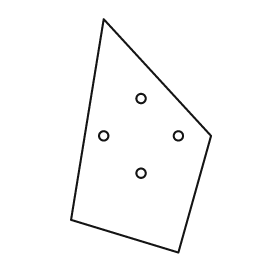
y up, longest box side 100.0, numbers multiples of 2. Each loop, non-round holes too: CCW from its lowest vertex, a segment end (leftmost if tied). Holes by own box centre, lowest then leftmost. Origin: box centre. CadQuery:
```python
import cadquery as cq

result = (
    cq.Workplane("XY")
    .moveTo(16.0, -50.0)
    .lineTo(30.0, 0.0)
    .lineTo(-16.0, 50.0)
    .lineTo(-30.0, -36.0)
    .close()
    .moveTo(0.0, -16.0)
    .circle(2.0)
    .moveTo(-16.0, 0.0)
    .circle(2.0)
    .moveTo(16.0, 0.0)
    .circle(2.0)
    .moveTo(0.0, 16.0)
    .circle(2.0)
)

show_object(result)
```